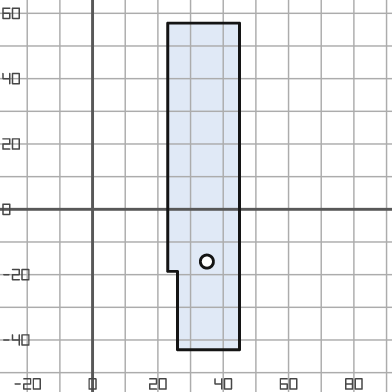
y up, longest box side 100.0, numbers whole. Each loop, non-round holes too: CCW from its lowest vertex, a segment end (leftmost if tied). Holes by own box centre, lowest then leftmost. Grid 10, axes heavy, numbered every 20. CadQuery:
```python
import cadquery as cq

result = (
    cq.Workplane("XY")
    .moveTo(26.0, -43.0)
    .lineTo(45.0, -43.0)
    .lineTo(45.0, 57.0)
    .lineTo(23.0, 57.0)
    .lineTo(23.0, -19.0)
    .lineTo(26.0, -19.0)
    .close()
    .moveTo(35.0, -16.0)
    .circle(2.0)
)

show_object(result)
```